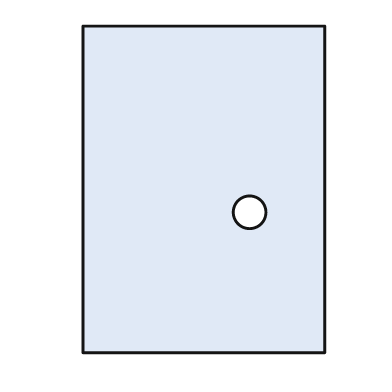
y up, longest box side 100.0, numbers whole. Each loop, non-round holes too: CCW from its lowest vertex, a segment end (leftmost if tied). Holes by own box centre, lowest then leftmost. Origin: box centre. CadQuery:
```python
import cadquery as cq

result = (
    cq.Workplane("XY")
    .moveTo(-37.0, -50.0)
    .lineTo(37.0, -50.0)
    .lineTo(37.0, 50.0)
    .lineTo(-37.0, 50.0)
    .close()
    .moveTo(14.0, -7.0)
    .circle(5.0)
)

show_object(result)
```